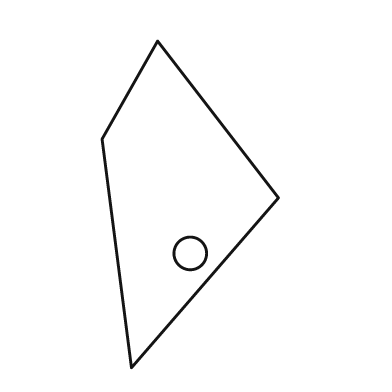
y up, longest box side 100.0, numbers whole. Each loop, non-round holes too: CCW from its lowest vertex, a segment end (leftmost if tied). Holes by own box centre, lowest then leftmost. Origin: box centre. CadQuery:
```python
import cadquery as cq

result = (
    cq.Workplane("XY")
    .moveTo(-18.0, -50.0)
    .lineTo(27.0, 2.0)
    .lineTo(-10.0, 50.0)
    .lineTo(-27.0, 20.0)
    .close()
    .moveTo(0.0, -15.0)
    .circle(5.0)
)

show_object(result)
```